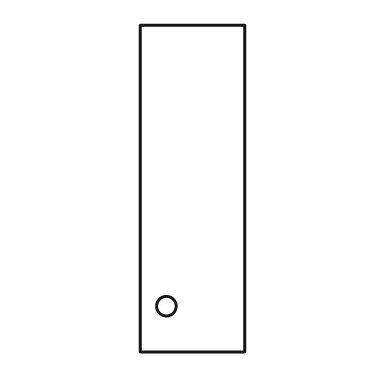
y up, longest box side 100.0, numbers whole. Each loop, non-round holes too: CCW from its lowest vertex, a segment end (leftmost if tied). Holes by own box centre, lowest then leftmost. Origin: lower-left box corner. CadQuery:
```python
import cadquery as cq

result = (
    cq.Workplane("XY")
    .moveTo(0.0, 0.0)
    .lineTo(32.0, 0.0)
    .lineTo(32.0, 100.0)
    .lineTo(0.0, 100.0)
    .close()
    .moveTo(8.0, 14.0)
    .circle(3.0)
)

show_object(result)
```